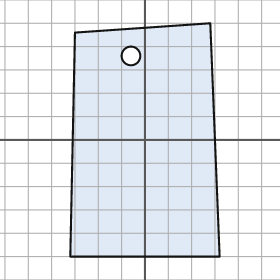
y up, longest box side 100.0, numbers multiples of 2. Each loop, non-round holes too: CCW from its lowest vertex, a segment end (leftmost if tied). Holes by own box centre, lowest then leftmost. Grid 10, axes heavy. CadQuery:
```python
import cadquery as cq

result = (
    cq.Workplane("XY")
    .moveTo(-32.0, -50.0)
    .lineTo(32.0, -50.0)
    .lineTo(28.0, 50.0)
    .lineTo(-30.0, 46.0)
    .close()
    .moveTo(-6.0, 36.0)
    .circle(4.0)
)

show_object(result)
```